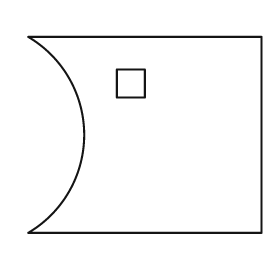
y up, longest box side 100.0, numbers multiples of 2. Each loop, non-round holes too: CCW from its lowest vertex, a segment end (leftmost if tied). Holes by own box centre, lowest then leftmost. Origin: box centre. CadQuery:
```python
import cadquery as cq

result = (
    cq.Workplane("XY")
    .moveTo(-50.0, -42.0)
    .lineTo(50.0, -42.0)
    .lineTo(50.0, 42.0)
    .lineTo(-50.0, 42.0)
    .threePointArc((-26.0, 0.0), (-50.0, -42.0))
    .close()
    .moveTo(-12.0, 16.0)
    .lineTo(0.0, 16.0)
    .lineTo(0.0, 28.0)
    .lineTo(-12.0, 28.0)
    .close()
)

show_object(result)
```